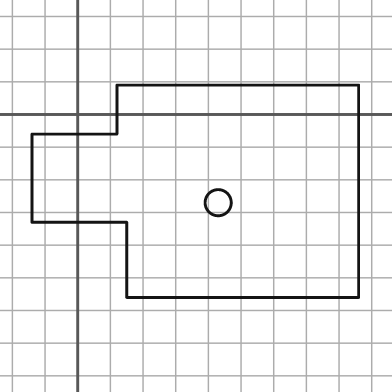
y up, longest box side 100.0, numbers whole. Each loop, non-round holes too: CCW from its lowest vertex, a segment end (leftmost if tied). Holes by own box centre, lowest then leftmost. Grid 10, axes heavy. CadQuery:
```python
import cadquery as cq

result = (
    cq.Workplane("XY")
    .moveTo(15.0, -56.0)
    .lineTo(86.0, -56.0)
    .lineTo(86.0, 9.0)
    .lineTo(12.0, 9.0)
    .lineTo(12.0, -6.0)
    .lineTo(-14.0, -6.0)
    .lineTo(-14.0, -33.0)
    .lineTo(15.0, -33.0)
    .close()
    .moveTo(43.0, -27.0)
    .circle(4.0)
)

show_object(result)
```